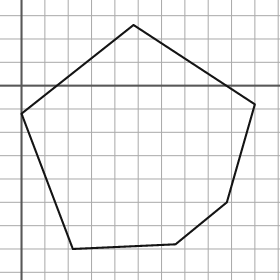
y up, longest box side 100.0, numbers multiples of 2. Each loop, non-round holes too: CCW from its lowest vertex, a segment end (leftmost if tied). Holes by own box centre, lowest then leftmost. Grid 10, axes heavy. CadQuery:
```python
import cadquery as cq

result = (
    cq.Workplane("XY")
    .moveTo(22.0, -70.0)
    .lineTo(66.0, -68.0)
    .lineTo(88.0, -50.0)
    .lineTo(100.0, -8.0)
    .lineTo(48.0, 26.0)
    .lineTo(0.0, -12.0)
    .close()
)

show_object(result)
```